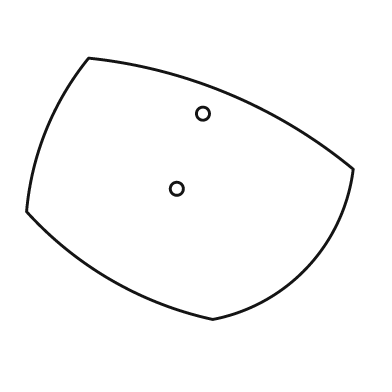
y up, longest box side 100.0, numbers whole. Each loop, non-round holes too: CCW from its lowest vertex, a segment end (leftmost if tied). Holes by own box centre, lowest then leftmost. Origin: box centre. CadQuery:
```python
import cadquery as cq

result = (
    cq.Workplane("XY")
    .moveTo(7.0, -40.0)
    .threePointArc((36.0, -24.0), (50.0, 6.0))
    .threePointArc((12.0, 29.0), (-31.0, 40.0))
    .threePointArc((-44.0, 18.0), (-50.0, -7.0))
    .threePointArc((-24.0, -28.0), (7.0, -40.0))
    .close()
    .moveTo(-4.0, 0.0)
    .circle(2.0)
    .moveTo(4.0, 23.0)
    .circle(2.0)
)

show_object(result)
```